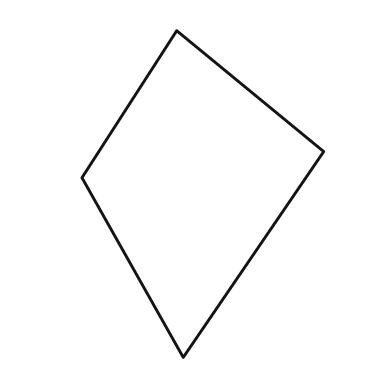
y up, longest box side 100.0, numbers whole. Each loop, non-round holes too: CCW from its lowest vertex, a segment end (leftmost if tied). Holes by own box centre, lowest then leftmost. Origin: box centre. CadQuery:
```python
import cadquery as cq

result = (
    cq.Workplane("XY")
    .moveTo(-6.0, -50.0)
    .lineTo(37.0, 13.0)
    .lineTo(-8.0, 50.0)
    .lineTo(-37.0, 5.0)
    .close()
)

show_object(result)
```